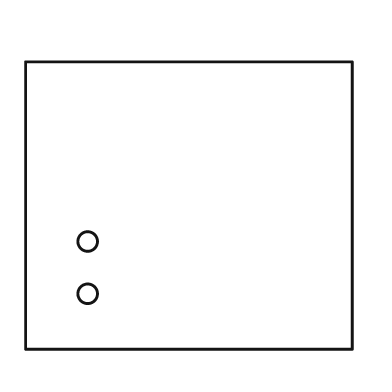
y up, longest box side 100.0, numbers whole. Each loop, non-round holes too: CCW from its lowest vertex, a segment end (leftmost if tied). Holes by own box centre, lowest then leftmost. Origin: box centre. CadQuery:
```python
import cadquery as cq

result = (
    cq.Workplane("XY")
    .moveTo(-50.0, -44.0)
    .lineTo(50.0, -44.0)
    .lineTo(50.0, 44.0)
    .lineTo(-50.0, 44.0)
    .close()
    .moveTo(-31.0, -27.0)
    .circle(3.0)
    .moveTo(-31.0, -11.0)
    .circle(3.0)
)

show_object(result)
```